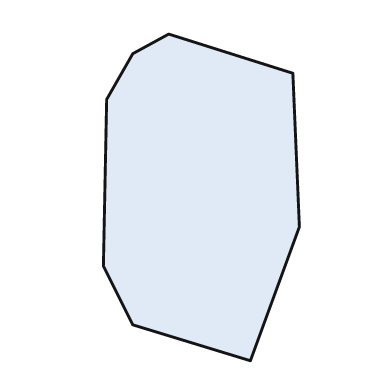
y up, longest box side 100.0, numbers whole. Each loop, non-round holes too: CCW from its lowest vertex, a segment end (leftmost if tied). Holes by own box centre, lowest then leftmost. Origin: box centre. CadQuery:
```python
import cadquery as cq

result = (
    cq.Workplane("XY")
    .moveTo(15.0, -50.0)
    .lineTo(30.0, -9.0)
    .lineTo(28.0, 38.0)
    .lineTo(-10.0, 50.0)
    .lineTo(-21.0, 44.0)
    .lineTo(-29.0, 30.0)
    .lineTo(-30.0, -21.0)
    .lineTo(-21.0, -39.0)
    .close()
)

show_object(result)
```